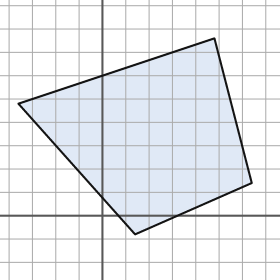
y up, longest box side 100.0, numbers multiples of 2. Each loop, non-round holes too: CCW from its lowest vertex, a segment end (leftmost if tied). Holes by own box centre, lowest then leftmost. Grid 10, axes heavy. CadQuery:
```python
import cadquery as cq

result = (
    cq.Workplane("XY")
    .moveTo(14.0, -8.0)
    .lineTo(64.0, 14.0)
    .lineTo(48.0, 76.0)
    .lineTo(-36.0, 48.0)
    .close()
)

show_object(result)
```